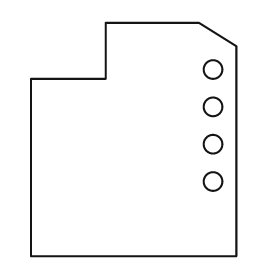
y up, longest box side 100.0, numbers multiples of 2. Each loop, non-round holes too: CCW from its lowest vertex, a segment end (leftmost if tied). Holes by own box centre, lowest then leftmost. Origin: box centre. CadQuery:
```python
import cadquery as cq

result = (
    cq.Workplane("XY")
    .moveTo(-44.0, -50.0)
    .lineTo(44.0, -50.0)
    .lineTo(44.0, 40.0)
    .lineTo(28.0, 50.0)
    .lineTo(-12.0, 50.0)
    .lineTo(-12.0, 26.0)
    .lineTo(-44.0, 26.0)
    .close()
    .moveTo(34.0, -18.0)
    .circle(4.0)
    .moveTo(34.0, -2.0)
    .circle(4.0)
    .moveTo(34.0, 14.0)
    .circle(4.0)
    .moveTo(34.0, 30.0)
    .circle(4.0)
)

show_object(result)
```